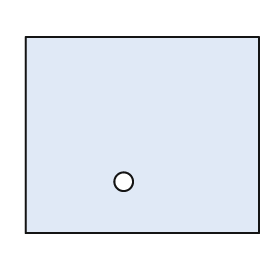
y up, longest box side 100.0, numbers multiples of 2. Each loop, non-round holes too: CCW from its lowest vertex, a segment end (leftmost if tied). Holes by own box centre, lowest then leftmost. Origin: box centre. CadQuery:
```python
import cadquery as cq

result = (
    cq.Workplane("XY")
    .moveTo(-50.0, -42.0)
    .lineTo(50.0, -42.0)
    .lineTo(50.0, 42.0)
    .lineTo(-50.0, 42.0)
    .close()
    .moveTo(-8.0, -20.0)
    .circle(4.0)
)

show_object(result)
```